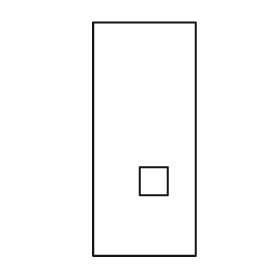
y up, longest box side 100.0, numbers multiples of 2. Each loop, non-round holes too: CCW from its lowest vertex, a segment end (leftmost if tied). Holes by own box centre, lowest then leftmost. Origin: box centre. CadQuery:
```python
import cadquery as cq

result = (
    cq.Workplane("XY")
    .moveTo(-22.0, -50.0)
    .lineTo(22.0, -50.0)
    .lineTo(22.0, 50.0)
    .lineTo(-22.0, 50.0)
    .close()
    .moveTo(-2.0, -24.0)
    .lineTo(10.0, -24.0)
    .lineTo(10.0, -12.0)
    .lineTo(-2.0, -12.0)
    .close()
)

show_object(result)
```